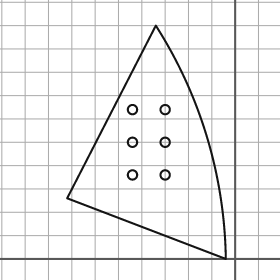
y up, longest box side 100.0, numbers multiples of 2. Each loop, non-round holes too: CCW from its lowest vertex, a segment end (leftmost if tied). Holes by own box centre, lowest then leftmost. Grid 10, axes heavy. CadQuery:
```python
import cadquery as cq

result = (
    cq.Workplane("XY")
    .moveTo(-4.0, 0.0)
    .threePointArc((-12.0, 52.0), (-34.0, 100.0))
    .lineTo(-72.0, 26.0)
    .close()
    .moveTo(-44.0, 36.0)
    .circle(2.0)
    .moveTo(-30.0, 36.0)
    .circle(2.0)
    .moveTo(-44.0, 50.0)
    .circle(2.0)
    .moveTo(-30.0, 50.0)
    .circle(2.0)
    .moveTo(-44.0, 64.0)
    .circle(2.0)
    .moveTo(-30.0, 64.0)
    .circle(2.0)
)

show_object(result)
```